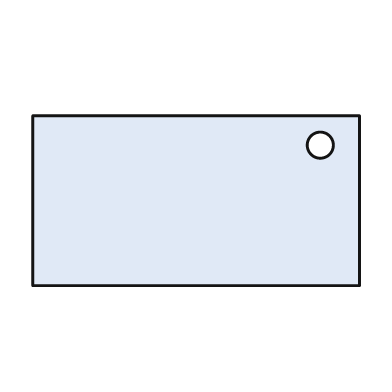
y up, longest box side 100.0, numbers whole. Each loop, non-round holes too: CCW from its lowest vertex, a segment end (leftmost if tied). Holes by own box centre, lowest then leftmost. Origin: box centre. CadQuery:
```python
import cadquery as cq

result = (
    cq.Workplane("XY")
    .moveTo(-50.0, -26.0)
    .lineTo(50.0, -26.0)
    .lineTo(50.0, 26.0)
    .lineTo(-50.0, 26.0)
    .close()
    .moveTo(38.0, 17.0)
    .circle(4.0)
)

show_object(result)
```